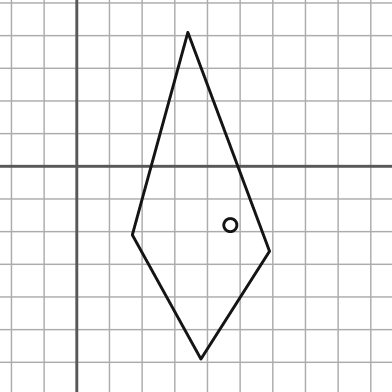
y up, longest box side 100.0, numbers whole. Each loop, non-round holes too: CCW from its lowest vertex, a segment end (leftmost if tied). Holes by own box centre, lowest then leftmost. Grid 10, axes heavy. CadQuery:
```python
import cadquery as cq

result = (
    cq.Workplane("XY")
    .moveTo(38.0, -59.0)
    .lineTo(59.0, -26.0)
    .lineTo(34.0, 41.0)
    .lineTo(17.0, -21.0)
    .close()
    .moveTo(47.0, -18.0)
    .circle(2.0)
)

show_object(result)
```